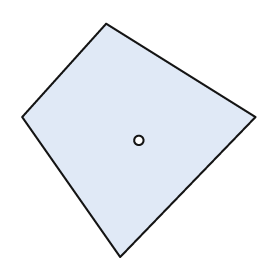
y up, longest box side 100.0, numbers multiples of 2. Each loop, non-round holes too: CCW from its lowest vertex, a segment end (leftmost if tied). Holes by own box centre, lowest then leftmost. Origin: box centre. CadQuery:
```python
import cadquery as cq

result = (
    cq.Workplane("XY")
    .moveTo(-8.0, -50.0)
    .lineTo(50.0, 10.0)
    .lineTo(-14.0, 50.0)
    .lineTo(-50.0, 10.0)
    .close()
    .moveTo(0.0, 0.0)
    .circle(2.0)
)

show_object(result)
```